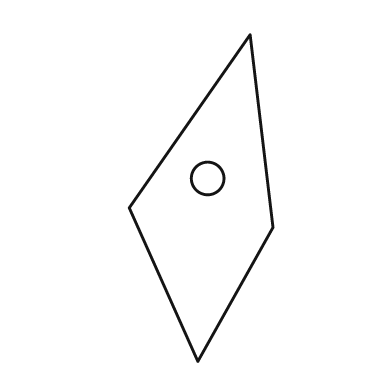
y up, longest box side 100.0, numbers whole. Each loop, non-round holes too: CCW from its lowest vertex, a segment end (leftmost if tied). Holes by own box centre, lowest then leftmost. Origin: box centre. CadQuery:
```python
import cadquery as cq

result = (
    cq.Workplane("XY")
    .moveTo(-1.0, -50.0)
    .lineTo(22.0, -9.0)
    .lineTo(15.0, 50.0)
    .lineTo(-22.0, -3.0)
    .close()
    .moveTo(2.0, 6.0)
    .circle(5.0)
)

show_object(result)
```